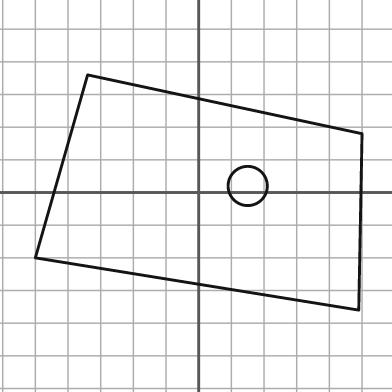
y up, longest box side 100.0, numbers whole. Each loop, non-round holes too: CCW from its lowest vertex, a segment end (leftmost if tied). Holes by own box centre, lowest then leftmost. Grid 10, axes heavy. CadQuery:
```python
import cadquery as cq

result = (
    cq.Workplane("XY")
    .moveTo(49.0, -36.0)
    .lineTo(50.0, 18.0)
    .lineTo(-34.0, 36.0)
    .lineTo(-50.0, -20.0)
    .close()
    .moveTo(15.0, 2.0)
    .circle(6.0)
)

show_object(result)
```